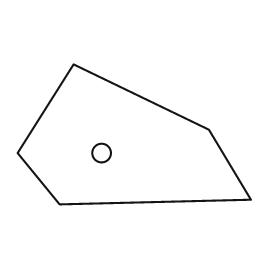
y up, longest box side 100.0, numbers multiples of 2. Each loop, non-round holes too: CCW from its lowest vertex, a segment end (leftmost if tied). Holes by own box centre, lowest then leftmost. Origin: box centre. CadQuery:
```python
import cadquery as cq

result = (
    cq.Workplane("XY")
    .moveTo(-32.0, -30.0)
    .lineTo(50.0, -28.0)
    .lineTo(32.0, 2.0)
    .lineTo(-26.0, 30.0)
    .lineTo(-50.0, -8.0)
    .close()
    .moveTo(-14.0, -8.0)
    .circle(4.0)
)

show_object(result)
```